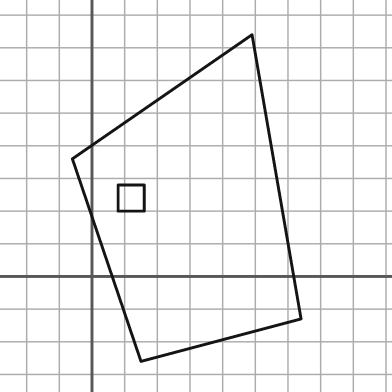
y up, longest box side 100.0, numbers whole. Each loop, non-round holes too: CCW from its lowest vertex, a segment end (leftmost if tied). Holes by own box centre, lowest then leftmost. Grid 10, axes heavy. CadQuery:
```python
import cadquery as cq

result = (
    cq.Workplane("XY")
    .moveTo(15.0, -26.0)
    .lineTo(64.0, -13.0)
    .lineTo(49.0, 74.0)
    .lineTo(-6.0, 36.0)
    .close()
    .moveTo(8.0, 20.0)
    .lineTo(16.0, 20.0)
    .lineTo(16.0, 28.0)
    .lineTo(8.0, 28.0)
    .close()
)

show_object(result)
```